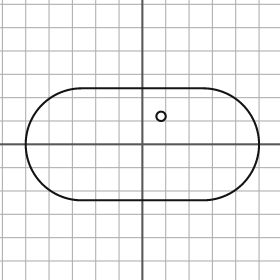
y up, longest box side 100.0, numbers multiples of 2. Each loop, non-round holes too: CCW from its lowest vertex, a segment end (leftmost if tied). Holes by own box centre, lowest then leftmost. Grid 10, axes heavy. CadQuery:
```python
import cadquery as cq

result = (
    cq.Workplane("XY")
    .moveTo(-26.0, -24.0)
    .lineTo(26.0, -24.0)
    .threePointArc((50.0, 0.0), (26.0, 24.0))
    .lineTo(-26.0, 24.0)
    .threePointArc((-50.0, 0.0), (-26.0, -24.0))
    .close()
    .moveTo(8.0, 12.0)
    .circle(2.0)
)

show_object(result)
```